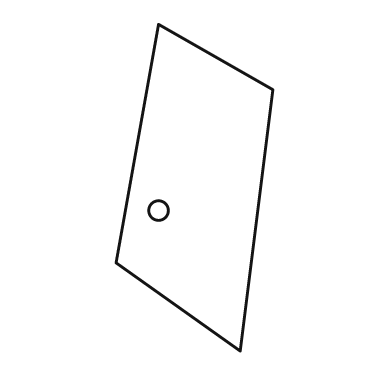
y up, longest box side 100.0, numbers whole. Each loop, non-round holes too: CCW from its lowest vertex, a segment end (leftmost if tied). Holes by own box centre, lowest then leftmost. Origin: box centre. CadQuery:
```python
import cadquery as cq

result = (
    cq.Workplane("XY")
    .moveTo(14.0, -50.0)
    .lineTo(24.0, 30.0)
    .lineTo(-11.0, 50.0)
    .lineTo(-24.0, -23.0)
    .close()
    .moveTo(-11.0, -7.0)
    .circle(3.0)
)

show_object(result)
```